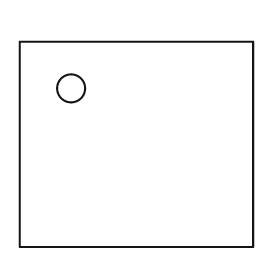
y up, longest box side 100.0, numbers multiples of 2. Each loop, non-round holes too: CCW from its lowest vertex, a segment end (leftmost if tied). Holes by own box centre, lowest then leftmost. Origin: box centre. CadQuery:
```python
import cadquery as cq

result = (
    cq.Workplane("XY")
    .moveTo(-50.0, -44.0)
    .lineTo(50.0, -44.0)
    .lineTo(50.0, 44.0)
    .lineTo(-50.0, 44.0)
    .close()
    .moveTo(-28.0, 24.0)
    .circle(6.0)
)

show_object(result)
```